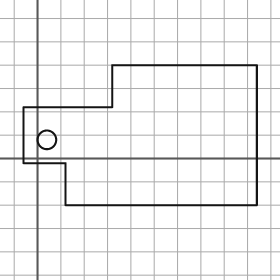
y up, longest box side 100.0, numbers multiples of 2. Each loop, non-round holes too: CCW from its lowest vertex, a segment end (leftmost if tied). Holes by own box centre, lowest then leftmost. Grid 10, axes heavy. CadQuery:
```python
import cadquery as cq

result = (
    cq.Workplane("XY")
    .moveTo(12.0, -20.0)
    .lineTo(94.0, -20.0)
    .lineTo(94.0, 40.0)
    .lineTo(32.0, 40.0)
    .lineTo(32.0, 22.0)
    .lineTo(-6.0, 22.0)
    .lineTo(-6.0, -2.0)
    .lineTo(12.0, -2.0)
    .close()
    .moveTo(4.0, 8.0)
    .circle(4.0)
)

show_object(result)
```